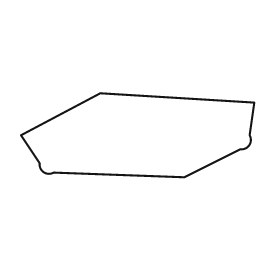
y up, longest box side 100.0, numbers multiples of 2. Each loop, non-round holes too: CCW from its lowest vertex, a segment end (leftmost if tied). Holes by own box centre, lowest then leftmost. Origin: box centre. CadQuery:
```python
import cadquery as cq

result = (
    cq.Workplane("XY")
    .moveTo(20.0, -18.0)
    .lineTo(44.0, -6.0)
    .threePointArc((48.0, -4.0), (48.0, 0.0))
    .lineTo(50.0, 14.0)
    .lineTo(-16.0, 18.0)
    .lineTo(-50.0, 0.0)
    .lineTo(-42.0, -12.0)
    .threePointArc((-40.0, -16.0), (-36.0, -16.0))
    .close()
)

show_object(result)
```